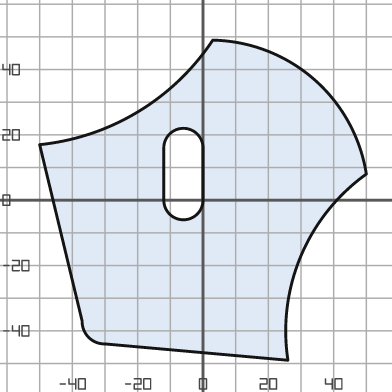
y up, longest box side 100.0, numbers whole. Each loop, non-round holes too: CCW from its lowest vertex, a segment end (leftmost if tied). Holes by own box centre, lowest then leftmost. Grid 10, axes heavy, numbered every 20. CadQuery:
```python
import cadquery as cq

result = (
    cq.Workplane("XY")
    .moveTo(26.0, -49.0)
    .threePointArc((30.0, -17.0), (50.0, 8.0))
    .threePointArc((34.0, 37.0), (3.0, 49.0))
    .threePointArc((-20.0, 27.0), (-50.0, 17.0))
    .lineTo(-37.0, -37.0)
    .threePointArc((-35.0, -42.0), (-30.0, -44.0))
    .close()
    .moveTo(-12.0, 0.0)
    .threePointArc((-6.0, -6.0), (0.0, 0.0))
    .lineTo(0.0, 16.0)
    .threePointArc((-6.0, 22.0), (-12.0, 16.0))
    .close()
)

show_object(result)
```